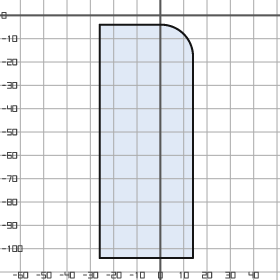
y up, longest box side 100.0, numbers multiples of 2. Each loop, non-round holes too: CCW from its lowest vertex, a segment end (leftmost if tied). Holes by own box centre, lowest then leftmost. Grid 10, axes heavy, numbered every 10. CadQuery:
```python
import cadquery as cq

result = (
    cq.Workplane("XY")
    .moveTo(-26.0, -104.0)
    .lineTo(14.0, -104.0)
    .lineTo(14.0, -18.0)
    .threePointArc((10.0, -8.0), (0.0, -4.0))
    .lineTo(-26.0, -4.0)
    .close()
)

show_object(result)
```